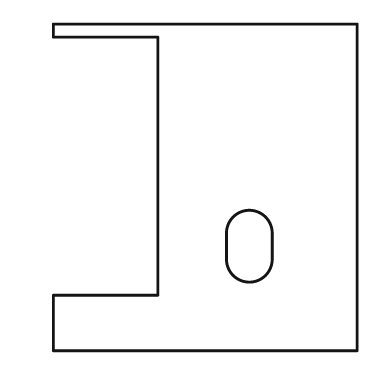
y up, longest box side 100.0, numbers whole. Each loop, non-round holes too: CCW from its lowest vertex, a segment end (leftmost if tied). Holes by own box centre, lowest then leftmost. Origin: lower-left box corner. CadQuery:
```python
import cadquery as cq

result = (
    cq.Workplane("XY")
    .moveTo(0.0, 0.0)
    .lineTo(93.0, 0.0)
    .lineTo(93.0, 100.0)
    .lineTo(0.0, 100.0)
    .lineTo(0.0, 96.0)
    .lineTo(32.0, 96.0)
    .lineTo(32.0, 17.0)
    .lineTo(0.0, 17.0)
    .close()
    .moveTo(53.0, 28.0)
    .threePointArc((60.0, 21.0), (67.0, 28.0))
    .lineTo(67.0, 36.0)
    .threePointArc((60.0, 43.0), (53.0, 36.0))
    .close()
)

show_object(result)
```